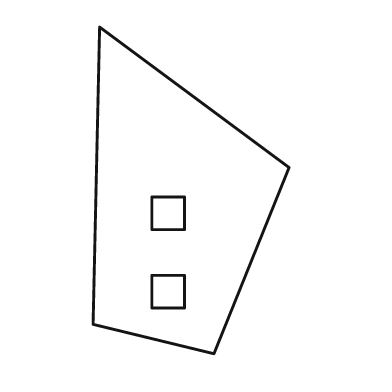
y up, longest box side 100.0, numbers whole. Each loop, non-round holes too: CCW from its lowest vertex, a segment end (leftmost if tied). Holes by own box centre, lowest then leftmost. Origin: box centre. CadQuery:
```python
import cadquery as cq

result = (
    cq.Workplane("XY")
    .moveTo(7.0, -50.0)
    .lineTo(30.0, 7.0)
    .lineTo(-28.0, 50.0)
    .lineTo(-30.0, -41.0)
    .close()
    .moveTo(-12.0, -36.0)
    .lineTo(-2.0, -36.0)
    .lineTo(-2.0, -26.0)
    .lineTo(-12.0, -26.0)
    .close()
    .moveTo(-12.0, -12.0)
    .lineTo(-2.0, -12.0)
    .lineTo(-2.0, -2.0)
    .lineTo(-12.0, -2.0)
    .close()
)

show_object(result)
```